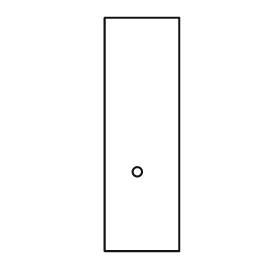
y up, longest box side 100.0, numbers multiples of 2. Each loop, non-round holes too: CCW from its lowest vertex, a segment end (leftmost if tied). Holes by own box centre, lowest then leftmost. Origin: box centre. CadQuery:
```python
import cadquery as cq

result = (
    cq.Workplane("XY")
    .moveTo(-16.0, -50.0)
    .lineTo(16.0, -50.0)
    .lineTo(16.0, 50.0)
    .lineTo(-16.0, 50.0)
    .close()
    .moveTo(-2.0, -16.0)
    .circle(2.0)
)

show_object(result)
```